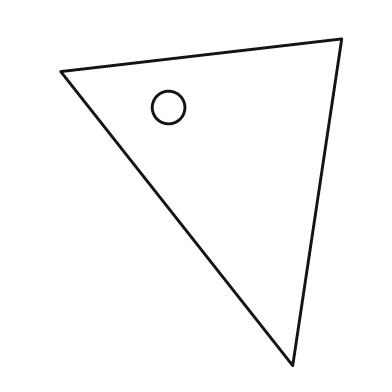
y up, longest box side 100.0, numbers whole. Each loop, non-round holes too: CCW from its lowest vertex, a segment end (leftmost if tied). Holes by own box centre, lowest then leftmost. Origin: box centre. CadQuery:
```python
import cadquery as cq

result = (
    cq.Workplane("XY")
    .moveTo(28.0, -50.0)
    .lineTo(43.0, 50.0)
    .lineTo(-43.0, 40.0)
    .close()
    .moveTo(-10.0, 29.0)
    .circle(5.0)
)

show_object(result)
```